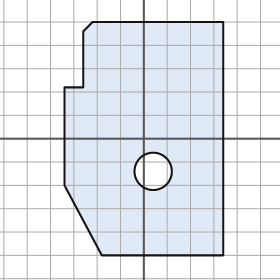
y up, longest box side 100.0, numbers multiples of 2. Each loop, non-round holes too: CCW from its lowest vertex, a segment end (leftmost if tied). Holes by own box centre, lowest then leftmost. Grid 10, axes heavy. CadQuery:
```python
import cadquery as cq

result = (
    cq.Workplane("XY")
    .moveTo(-18.0, -50.0)
    .lineTo(34.0, -50.0)
    .lineTo(34.0, 50.0)
    .lineTo(-22.0, 50.0)
    .lineTo(-26.0, 46.0)
    .lineTo(-26.0, 22.0)
    .lineTo(-34.0, 22.0)
    .lineTo(-34.0, -20.0)
    .close()
    .moveTo(4.0, -14.0)
    .circle(8.0)
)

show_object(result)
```